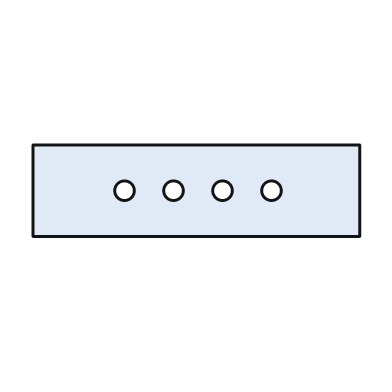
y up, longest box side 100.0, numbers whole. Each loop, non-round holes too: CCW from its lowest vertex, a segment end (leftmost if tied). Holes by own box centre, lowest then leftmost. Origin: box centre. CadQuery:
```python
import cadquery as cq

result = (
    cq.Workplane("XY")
    .moveTo(-50.0, -14.0)
    .lineTo(50.0, -14.0)
    .lineTo(50.0, 14.0)
    .lineTo(-50.0, 14.0)
    .close()
    .moveTo(-22.0, 0.0)
    .circle(3.0)
    .moveTo(-7.0, 0.0)
    .circle(3.0)
    .moveTo(8.0, 0.0)
    .circle(3.0)
    .moveTo(23.0, 0.0)
    .circle(3.0)
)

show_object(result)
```